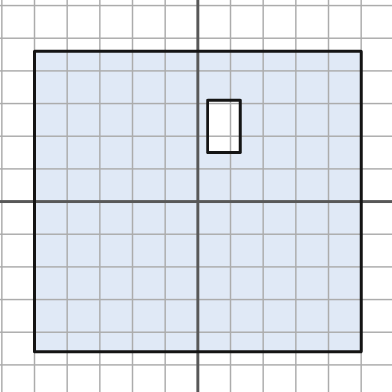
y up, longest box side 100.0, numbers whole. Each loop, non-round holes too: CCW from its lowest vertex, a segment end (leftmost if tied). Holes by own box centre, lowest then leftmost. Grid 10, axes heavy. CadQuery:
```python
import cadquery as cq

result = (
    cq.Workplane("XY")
    .moveTo(-50.0, -46.0)
    .lineTo(50.0, -46.0)
    .lineTo(50.0, 46.0)
    .lineTo(-50.0, 46.0)
    .close()
    .moveTo(3.0, 15.0)
    .lineTo(13.0, 15.0)
    .lineTo(13.0, 31.0)
    .lineTo(3.0, 31.0)
    .close()
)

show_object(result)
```